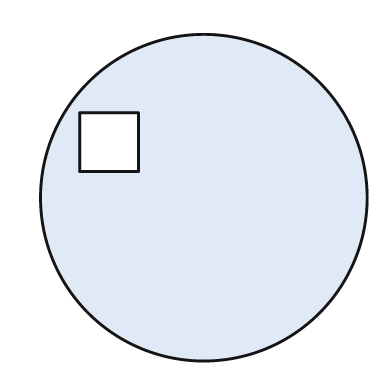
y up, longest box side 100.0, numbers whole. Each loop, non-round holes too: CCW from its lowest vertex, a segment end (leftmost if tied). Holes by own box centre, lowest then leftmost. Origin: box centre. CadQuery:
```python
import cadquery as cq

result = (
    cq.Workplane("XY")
    .moveTo(0.0, 0.0)
    .circle(50.0)
    .moveTo(-38.0, 8.0)
    .lineTo(-20.0, 8.0)
    .lineTo(-20.0, 26.0)
    .lineTo(-38.0, 26.0)
    .close()
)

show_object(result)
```